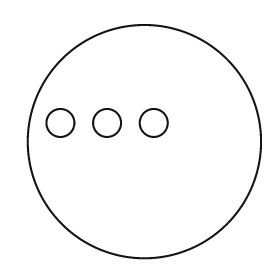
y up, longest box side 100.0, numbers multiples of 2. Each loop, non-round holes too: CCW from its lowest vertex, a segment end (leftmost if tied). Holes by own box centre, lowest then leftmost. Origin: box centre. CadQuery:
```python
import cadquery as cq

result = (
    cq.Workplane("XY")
    .moveTo(0.0, 0.0)
    .circle(50.0)
    .moveTo(-36.0, 8.0)
    .circle(6.0)
    .moveTo(-16.0, 8.0)
    .circle(6.0)
    .moveTo(4.0, 8.0)
    .circle(6.0)
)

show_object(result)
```